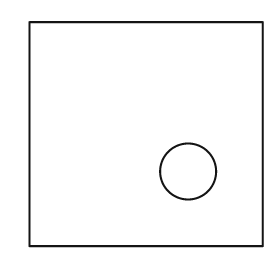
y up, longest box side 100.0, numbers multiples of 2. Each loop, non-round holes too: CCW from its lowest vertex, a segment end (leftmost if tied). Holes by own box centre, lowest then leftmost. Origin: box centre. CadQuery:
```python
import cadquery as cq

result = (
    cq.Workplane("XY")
    .moveTo(-50.0, -48.0)
    .lineTo(50.0, -48.0)
    .lineTo(50.0, 48.0)
    .lineTo(-50.0, 48.0)
    .close()
    .moveTo(18.0, -16.0)
    .circle(12.0)
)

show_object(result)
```